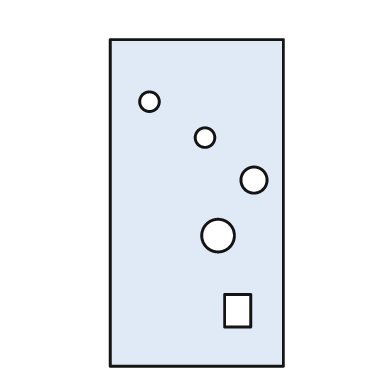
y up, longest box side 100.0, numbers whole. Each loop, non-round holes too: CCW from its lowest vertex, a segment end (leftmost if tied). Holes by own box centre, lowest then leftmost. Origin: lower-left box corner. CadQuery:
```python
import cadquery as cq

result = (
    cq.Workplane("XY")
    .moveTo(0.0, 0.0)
    .lineTo(53.0, 0.0)
    .lineTo(53.0, 100.0)
    .lineTo(0.0, 100.0)
    .close()
    .moveTo(35.0, 12.0)
    .lineTo(43.0, 12.0)
    .lineTo(43.0, 22.0)
    .lineTo(35.0, 22.0)
    .close()
    .moveTo(33.0, 40.0)
    .circle(5.0)
    .moveTo(44.0, 57.0)
    .circle(4.0)
    .moveTo(29.0, 70.0)
    .circle(3.0)
    .moveTo(12.0, 81.0)
    .circle(3.0)
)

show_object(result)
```